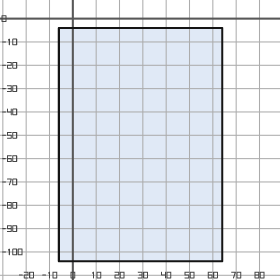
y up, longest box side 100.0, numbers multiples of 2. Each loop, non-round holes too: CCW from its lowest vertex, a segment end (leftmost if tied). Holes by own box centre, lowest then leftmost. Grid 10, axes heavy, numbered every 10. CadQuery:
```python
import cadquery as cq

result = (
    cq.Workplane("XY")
    .moveTo(-6.0, -104.0)
    .lineTo(64.0, -104.0)
    .lineTo(64.0, -4.0)
    .lineTo(-6.0, -4.0)
    .close()
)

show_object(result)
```